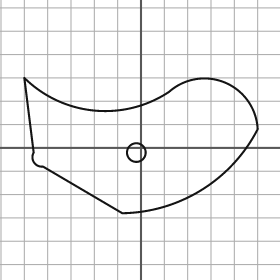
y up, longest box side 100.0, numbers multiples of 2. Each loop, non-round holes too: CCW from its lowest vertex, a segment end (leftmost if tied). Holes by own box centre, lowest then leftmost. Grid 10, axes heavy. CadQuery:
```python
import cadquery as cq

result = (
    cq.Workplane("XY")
    .moveTo(-8.0, -28.0)
    .threePointArc((26.0, -18.0), (50.0, 8.0))
    .threePointArc((36.0, 28.0), (12.0, 24.0))
    .threePointArc((-20.0, 16.0), (-50.0, 30.0))
    .lineTo(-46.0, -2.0)
    .threePointArc((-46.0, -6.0), (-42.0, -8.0))
    .close()
    .moveTo(-2.0, -2.0)
    .circle(4.0)
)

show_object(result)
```